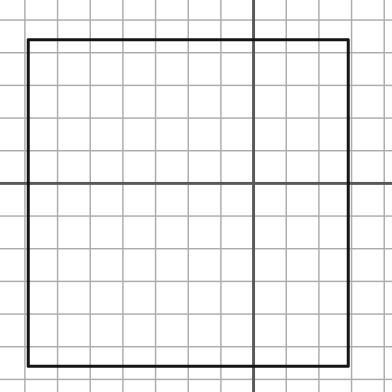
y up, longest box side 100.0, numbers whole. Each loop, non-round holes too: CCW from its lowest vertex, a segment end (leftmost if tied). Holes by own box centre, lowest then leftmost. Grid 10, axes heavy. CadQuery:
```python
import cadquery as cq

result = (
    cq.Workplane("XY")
    .moveTo(-69.0, -56.0)
    .lineTo(29.0, -56.0)
    .lineTo(29.0, 44.0)
    .lineTo(-69.0, 44.0)
    .close()
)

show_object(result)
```